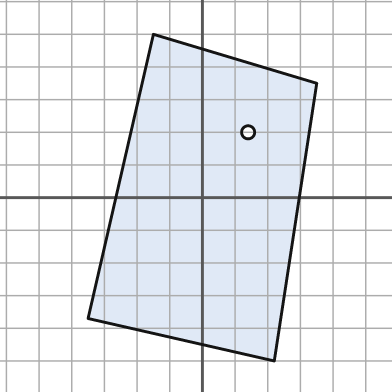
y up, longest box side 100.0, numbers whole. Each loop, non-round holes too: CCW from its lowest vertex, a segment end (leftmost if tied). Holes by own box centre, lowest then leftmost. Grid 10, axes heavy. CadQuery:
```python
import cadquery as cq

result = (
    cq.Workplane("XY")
    .moveTo(22.0, -50.0)
    .lineTo(35.0, 35.0)
    .lineTo(-15.0, 50.0)
    .lineTo(-35.0, -37.0)
    .close()
    .moveTo(14.0, 20.0)
    .circle(2.0)
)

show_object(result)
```